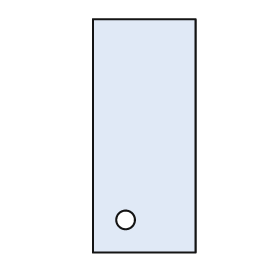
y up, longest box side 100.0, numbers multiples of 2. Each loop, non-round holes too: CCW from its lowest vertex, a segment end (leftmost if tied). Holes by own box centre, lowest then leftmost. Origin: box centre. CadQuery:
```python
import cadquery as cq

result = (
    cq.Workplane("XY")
    .moveTo(-22.0, -50.0)
    .lineTo(22.0, -50.0)
    .lineTo(22.0, 50.0)
    .lineTo(-22.0, 50.0)
    .close()
    .moveTo(-8.0, -36.0)
    .circle(4.0)
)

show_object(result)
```